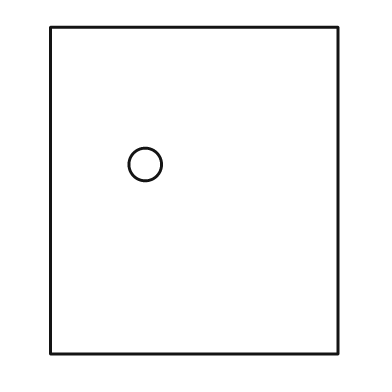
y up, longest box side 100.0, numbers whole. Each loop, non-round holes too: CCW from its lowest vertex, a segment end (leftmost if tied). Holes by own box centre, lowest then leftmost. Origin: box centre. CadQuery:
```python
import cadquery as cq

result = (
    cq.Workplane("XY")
    .moveTo(-44.0, -50.0)
    .lineTo(44.0, -50.0)
    .lineTo(44.0, 50.0)
    .lineTo(-44.0, 50.0)
    .close()
    .moveTo(-15.0, 8.0)
    .circle(5.0)
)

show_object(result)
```